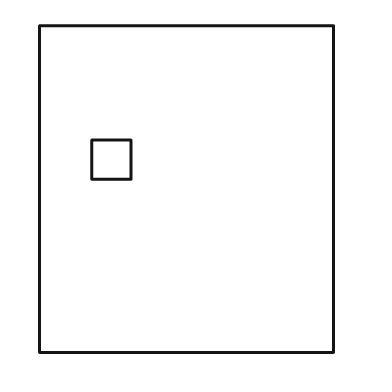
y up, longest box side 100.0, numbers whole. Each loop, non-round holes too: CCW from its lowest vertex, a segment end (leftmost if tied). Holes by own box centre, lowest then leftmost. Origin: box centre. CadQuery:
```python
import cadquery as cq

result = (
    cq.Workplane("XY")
    .moveTo(-45.0, -50.0)
    .lineTo(45.0, -50.0)
    .lineTo(45.0, 50.0)
    .lineTo(-45.0, 50.0)
    .close()
    .moveTo(-29.0, 3.0)
    .lineTo(-17.0, 3.0)
    .lineTo(-17.0, 15.0)
    .lineTo(-29.0, 15.0)
    .close()
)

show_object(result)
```